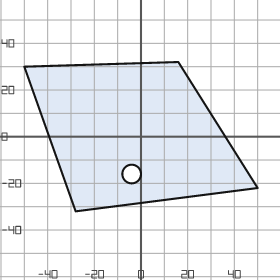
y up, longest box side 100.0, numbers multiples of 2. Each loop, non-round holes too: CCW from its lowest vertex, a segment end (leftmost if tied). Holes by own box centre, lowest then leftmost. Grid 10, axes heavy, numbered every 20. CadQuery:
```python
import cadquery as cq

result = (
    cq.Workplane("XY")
    .moveTo(-28.0, -32.0)
    .lineTo(50.0, -22.0)
    .lineTo(16.0, 32.0)
    .lineTo(-50.0, 30.0)
    .close()
    .moveTo(-4.0, -16.0)
    .circle(4.0)
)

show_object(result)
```